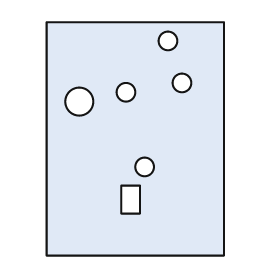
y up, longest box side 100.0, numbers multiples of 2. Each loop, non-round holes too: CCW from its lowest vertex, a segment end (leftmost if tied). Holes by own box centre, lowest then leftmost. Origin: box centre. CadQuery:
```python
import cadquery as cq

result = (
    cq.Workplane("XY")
    .moveTo(-38.0, -50.0)
    .lineTo(38.0, -50.0)
    .lineTo(38.0, 50.0)
    .lineTo(-38.0, 50.0)
    .close()
    .moveTo(-6.0, -32.0)
    .lineTo(2.0, -32.0)
    .lineTo(2.0, -20.0)
    .lineTo(-6.0, -20.0)
    .close()
    .moveTo(4.0, -12.0)
    .circle(4.0)
    .moveTo(-24.0, 16.0)
    .circle(6.0)
    .moveTo(-4.0, 20.0)
    .circle(4.0)
    .moveTo(20.0, 24.0)
    .circle(4.0)
    .moveTo(14.0, 42.0)
    .circle(4.0)
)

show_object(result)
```